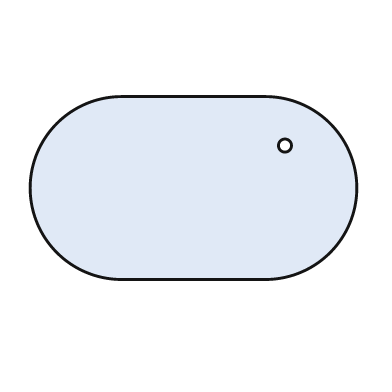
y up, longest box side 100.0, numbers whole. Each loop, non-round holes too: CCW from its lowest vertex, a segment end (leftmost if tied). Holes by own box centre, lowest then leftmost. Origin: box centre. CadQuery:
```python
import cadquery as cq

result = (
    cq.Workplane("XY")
    .moveTo(-22.0, -28.0)
    .lineTo(22.0, -28.0)
    .threePointArc((50.0, 0.0), (22.0, 28.0))
    .lineTo(-22.0, 28.0)
    .threePointArc((-50.0, 0.0), (-22.0, -28.0))
    .close()
    .moveTo(28.0, 13.0)
    .circle(2.0)
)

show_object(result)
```